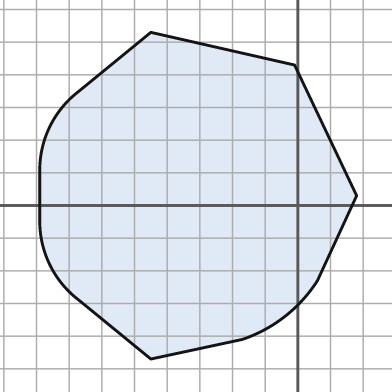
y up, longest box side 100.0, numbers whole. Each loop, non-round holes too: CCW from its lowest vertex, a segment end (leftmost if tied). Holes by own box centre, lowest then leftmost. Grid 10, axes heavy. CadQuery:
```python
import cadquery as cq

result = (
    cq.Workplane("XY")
    .moveTo(-45.0, -47.0)
    .lineTo(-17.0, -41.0)
    .threePointArc((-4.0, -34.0), (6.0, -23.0))
    .lineTo(18.0, 3.0)
    .lineTo(-1.0, 43.0)
    .lineTo(-45.0, 53.0)
    .lineTo(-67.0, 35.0)
    .threePointArc((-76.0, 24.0), (-79.0, 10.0))
    .lineTo(-79.0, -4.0)
    .threePointArc((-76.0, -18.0), (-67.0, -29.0))
    .close()
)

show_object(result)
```